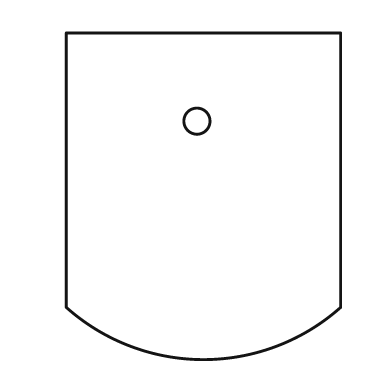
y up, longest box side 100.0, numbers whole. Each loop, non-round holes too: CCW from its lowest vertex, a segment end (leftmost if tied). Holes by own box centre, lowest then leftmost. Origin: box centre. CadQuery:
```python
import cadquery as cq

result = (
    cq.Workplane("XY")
    .moveTo(-42.0, -34.0)
    .threePointArc((0.0, -50.0), (42.0, -34.0))
    .lineTo(42.0, 50.0)
    .lineTo(-42.0, 50.0)
    .close()
    .moveTo(-2.0, 23.0)
    .circle(4.0)
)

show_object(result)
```